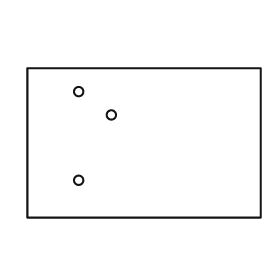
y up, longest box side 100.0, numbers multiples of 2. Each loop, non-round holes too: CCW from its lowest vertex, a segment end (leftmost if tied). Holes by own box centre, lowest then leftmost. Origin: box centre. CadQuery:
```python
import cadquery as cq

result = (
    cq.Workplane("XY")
    .moveTo(-50.0, -32.0)
    .lineTo(50.0, -32.0)
    .lineTo(50.0, 32.0)
    .lineTo(-50.0, 32.0)
    .close()
    .moveTo(-28.0, -16.0)
    .circle(2.0)
    .moveTo(-14.0, 12.0)
    .circle(2.0)
    .moveTo(-28.0, 22.0)
    .circle(2.0)
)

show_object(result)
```